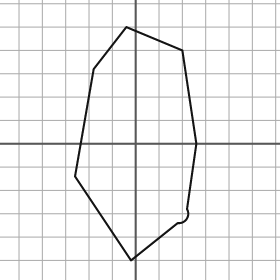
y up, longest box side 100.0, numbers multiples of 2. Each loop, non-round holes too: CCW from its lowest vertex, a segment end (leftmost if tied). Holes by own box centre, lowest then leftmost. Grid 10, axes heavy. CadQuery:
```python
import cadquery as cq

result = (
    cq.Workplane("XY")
    .moveTo(-2.0, -50.0)
    .lineTo(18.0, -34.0)
    .threePointArc((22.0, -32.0), (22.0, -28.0))
    .lineTo(26.0, 0.0)
    .lineTo(20.0, 40.0)
    .lineTo(-4.0, 50.0)
    .lineTo(-18.0, 32.0)
    .lineTo(-26.0, -14.0)
    .close()
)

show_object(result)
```